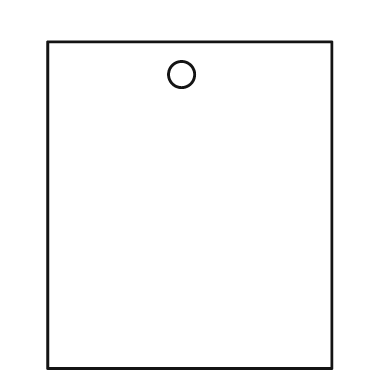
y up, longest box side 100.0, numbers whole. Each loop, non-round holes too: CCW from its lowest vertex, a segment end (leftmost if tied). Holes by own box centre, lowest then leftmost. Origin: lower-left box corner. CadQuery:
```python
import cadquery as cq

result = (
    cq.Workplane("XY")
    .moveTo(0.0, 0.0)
    .lineTo(87.0, 0.0)
    .lineTo(87.0, 100.0)
    .lineTo(0.0, 100.0)
    .close()
    .moveTo(41.0, 90.0)
    .circle(4.0)
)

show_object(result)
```